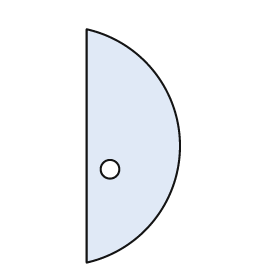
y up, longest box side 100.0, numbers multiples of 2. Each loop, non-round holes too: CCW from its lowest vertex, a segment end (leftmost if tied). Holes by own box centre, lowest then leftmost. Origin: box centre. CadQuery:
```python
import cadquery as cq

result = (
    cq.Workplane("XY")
    .moveTo(-20.0, -50.0)
    .threePointArc((20.0, 0.0), (-20.0, 50.0))
    .close()
    .moveTo(-10.0, -10.0)
    .circle(4.0)
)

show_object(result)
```